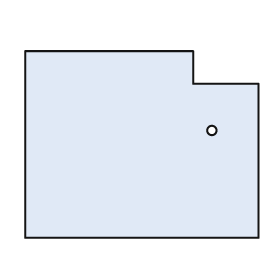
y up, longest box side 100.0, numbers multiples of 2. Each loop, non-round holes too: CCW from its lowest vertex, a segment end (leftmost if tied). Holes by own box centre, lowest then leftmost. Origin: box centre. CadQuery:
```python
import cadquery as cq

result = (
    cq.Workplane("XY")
    .moveTo(-50.0, -40.0)
    .lineTo(50.0, -40.0)
    .lineTo(50.0, 26.0)
    .lineTo(22.0, 26.0)
    .lineTo(22.0, 40.0)
    .lineTo(-50.0, 40.0)
    .close()
    .moveTo(30.0, 6.0)
    .circle(2.0)
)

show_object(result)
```